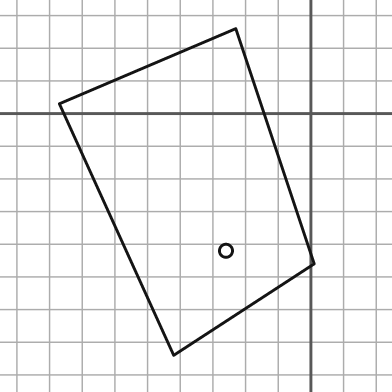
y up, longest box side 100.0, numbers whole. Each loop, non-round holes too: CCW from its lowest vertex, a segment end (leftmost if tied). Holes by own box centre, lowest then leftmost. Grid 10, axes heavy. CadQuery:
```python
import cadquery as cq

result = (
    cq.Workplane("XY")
    .moveTo(-42.0, -74.0)
    .lineTo(1.0, -46.0)
    .lineTo(-23.0, 26.0)
    .lineTo(-77.0, 3.0)
    .close()
    .moveTo(-26.0, -42.0)
    .circle(2.0)
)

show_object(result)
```